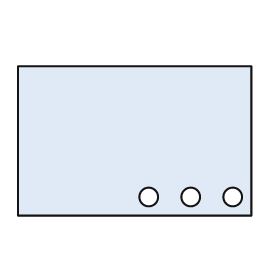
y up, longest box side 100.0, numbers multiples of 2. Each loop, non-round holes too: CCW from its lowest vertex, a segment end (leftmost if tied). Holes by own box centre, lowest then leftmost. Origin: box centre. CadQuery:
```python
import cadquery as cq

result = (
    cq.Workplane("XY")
    .moveTo(-50.0, -32.0)
    .lineTo(50.0, -32.0)
    .lineTo(50.0, 32.0)
    .lineTo(-50.0, 32.0)
    .close()
    .moveTo(6.0, -24.0)
    .circle(4.0)
    .moveTo(24.0, -24.0)
    .circle(4.0)
    .moveTo(42.0, -24.0)
    .circle(4.0)
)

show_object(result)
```